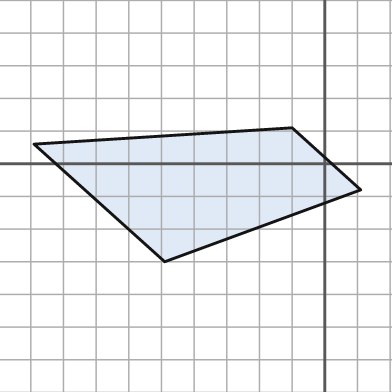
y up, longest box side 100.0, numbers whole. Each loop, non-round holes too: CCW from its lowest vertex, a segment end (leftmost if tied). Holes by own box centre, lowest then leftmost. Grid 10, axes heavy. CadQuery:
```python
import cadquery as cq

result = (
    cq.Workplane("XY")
    .moveTo(-49.0, -30.0)
    .lineTo(11.0, -8.0)
    .lineTo(-10.0, 11.0)
    .lineTo(-89.0, 6.0)
    .close()
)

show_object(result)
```